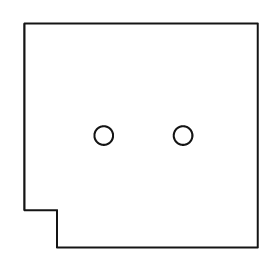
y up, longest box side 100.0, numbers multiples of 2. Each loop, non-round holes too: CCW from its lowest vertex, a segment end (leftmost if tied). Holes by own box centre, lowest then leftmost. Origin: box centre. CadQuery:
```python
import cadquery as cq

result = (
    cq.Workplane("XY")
    .moveTo(-36.0, -48.0)
    .lineTo(50.0, -48.0)
    .lineTo(50.0, 48.0)
    .lineTo(-50.0, 48.0)
    .lineTo(-50.0, -32.0)
    .lineTo(-36.0, -32.0)
    .close()
    .moveTo(-16.0, 0.0)
    .circle(4.0)
    .moveTo(18.0, 0.0)
    .circle(4.0)
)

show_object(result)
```